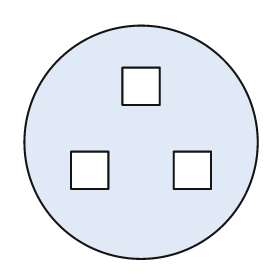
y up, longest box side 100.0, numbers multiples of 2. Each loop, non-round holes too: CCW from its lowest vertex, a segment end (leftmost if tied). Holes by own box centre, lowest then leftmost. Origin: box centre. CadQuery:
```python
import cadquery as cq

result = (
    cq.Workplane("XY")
    .moveTo(0.0, 0.0)
    .circle(50.0)
    .moveTo(-30.0, -20.0)
    .lineTo(-14.0, -20.0)
    .lineTo(-14.0, -4.0)
    .lineTo(-30.0, -4.0)
    .close()
    .moveTo(14.0, -20.0)
    .lineTo(30.0, -20.0)
    .lineTo(30.0, -4.0)
    .lineTo(14.0, -4.0)
    .close()
    .moveTo(-8.0, 16.0)
    .lineTo(8.0, 16.0)
    .lineTo(8.0, 32.0)
    .lineTo(-8.0, 32.0)
    .close()
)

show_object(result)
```